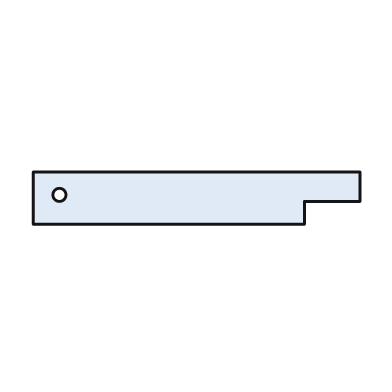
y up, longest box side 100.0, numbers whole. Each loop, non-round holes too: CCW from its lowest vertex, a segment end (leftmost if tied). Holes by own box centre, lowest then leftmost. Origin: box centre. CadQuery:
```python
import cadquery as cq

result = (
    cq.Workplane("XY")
    .moveTo(-50.0, -8.0)
    .lineTo(33.0, -8.0)
    .lineTo(33.0, -1.0)
    .lineTo(50.0, -1.0)
    .lineTo(50.0, 8.0)
    .lineTo(-50.0, 8.0)
    .close()
    .moveTo(-42.0, 1.0)
    .circle(2.0)
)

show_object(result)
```